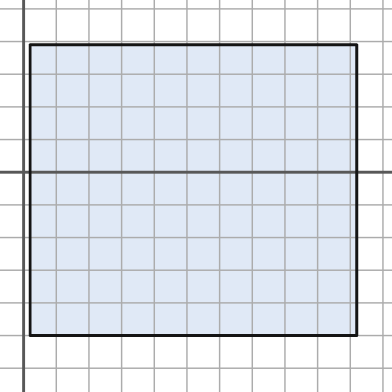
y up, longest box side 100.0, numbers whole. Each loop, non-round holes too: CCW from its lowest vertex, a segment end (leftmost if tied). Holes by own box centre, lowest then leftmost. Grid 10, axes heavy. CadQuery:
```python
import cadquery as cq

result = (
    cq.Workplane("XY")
    .moveTo(2.0, -50.0)
    .lineTo(102.0, -50.0)
    .lineTo(102.0, 39.0)
    .lineTo(2.0, 39.0)
    .close()
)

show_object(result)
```